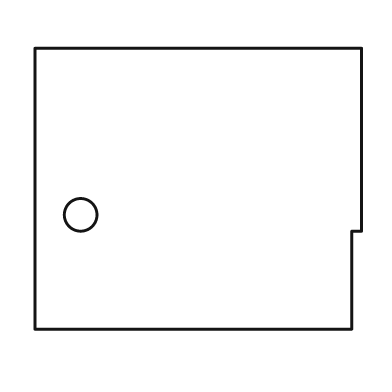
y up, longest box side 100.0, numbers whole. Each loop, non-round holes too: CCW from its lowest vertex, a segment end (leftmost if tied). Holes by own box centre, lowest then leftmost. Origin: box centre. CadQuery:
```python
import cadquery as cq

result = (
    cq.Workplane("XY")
    .moveTo(-50.0, -43.0)
    .lineTo(47.0, -43.0)
    .lineTo(47.0, -13.0)
    .lineTo(50.0, -13.0)
    .lineTo(50.0, 43.0)
    .lineTo(-50.0, 43.0)
    .close()
    .moveTo(-36.0, -8.0)
    .circle(5.0)
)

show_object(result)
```